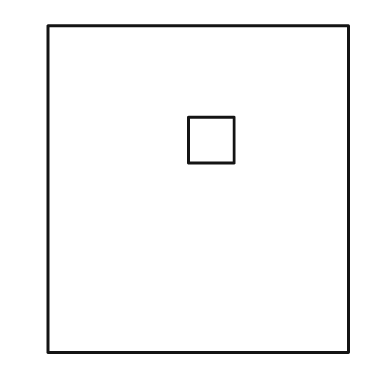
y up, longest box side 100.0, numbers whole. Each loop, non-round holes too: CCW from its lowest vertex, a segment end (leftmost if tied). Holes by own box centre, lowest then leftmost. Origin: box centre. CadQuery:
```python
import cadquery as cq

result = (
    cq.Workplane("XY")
    .moveTo(-46.0, -50.0)
    .lineTo(46.0, -50.0)
    .lineTo(46.0, 50.0)
    .lineTo(-46.0, 50.0)
    .close()
    .moveTo(-3.0, 8.0)
    .lineTo(11.0, 8.0)
    .lineTo(11.0, 22.0)
    .lineTo(-3.0, 22.0)
    .close()
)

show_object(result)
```